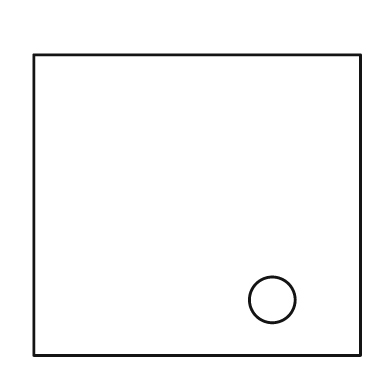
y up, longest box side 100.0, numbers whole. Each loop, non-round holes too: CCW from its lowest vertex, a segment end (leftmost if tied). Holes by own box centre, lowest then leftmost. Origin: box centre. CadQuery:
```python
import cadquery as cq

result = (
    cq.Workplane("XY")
    .moveTo(-50.0, -46.0)
    .lineTo(50.0, -46.0)
    .lineTo(50.0, 46.0)
    .lineTo(-50.0, 46.0)
    .close()
    .moveTo(23.0, -29.0)
    .circle(7.0)
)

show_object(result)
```